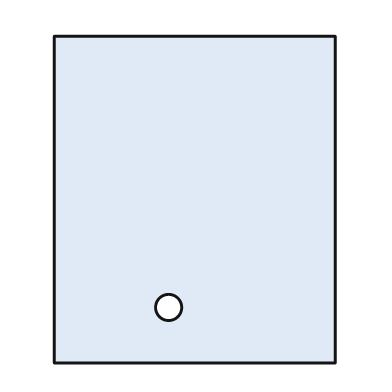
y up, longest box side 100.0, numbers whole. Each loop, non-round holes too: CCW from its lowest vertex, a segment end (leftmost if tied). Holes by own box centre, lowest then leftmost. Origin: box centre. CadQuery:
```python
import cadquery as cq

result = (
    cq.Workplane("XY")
    .moveTo(-43.0, -50.0)
    .lineTo(43.0, -50.0)
    .lineTo(43.0, 50.0)
    .lineTo(-43.0, 50.0)
    .close()
    .moveTo(-8.0, -33.0)
    .circle(4.0)
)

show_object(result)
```